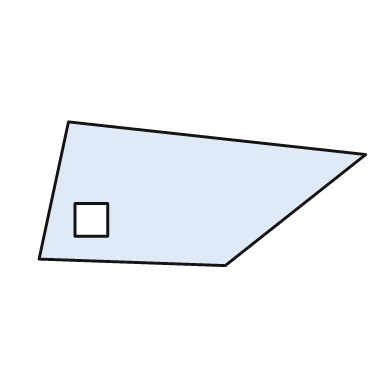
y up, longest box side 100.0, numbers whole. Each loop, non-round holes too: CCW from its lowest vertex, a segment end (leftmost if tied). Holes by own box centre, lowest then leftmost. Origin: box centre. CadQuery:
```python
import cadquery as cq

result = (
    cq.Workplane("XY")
    .moveTo(7.0, -22.0)
    .lineTo(50.0, 12.0)
    .lineTo(-41.0, 22.0)
    .lineTo(-50.0, -20.0)
    .close()
    .moveTo(-39.0, -13.0)
    .lineTo(-29.0, -13.0)
    .lineTo(-29.0, -3.0)
    .lineTo(-39.0, -3.0)
    .close()
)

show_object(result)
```